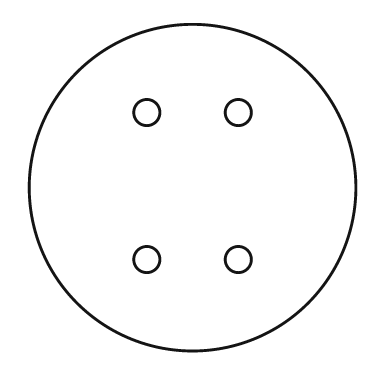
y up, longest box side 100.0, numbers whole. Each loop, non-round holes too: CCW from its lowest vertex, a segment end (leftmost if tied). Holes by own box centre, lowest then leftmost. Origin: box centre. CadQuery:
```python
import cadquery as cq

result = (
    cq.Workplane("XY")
    .moveTo(0.0, 0.0)
    .circle(50.0)
    .moveTo(-14.0, -22.0)
    .circle(4.0)
    .moveTo(14.0, -22.0)
    .circle(4.0)
    .moveTo(-14.0, 23.0)
    .circle(4.0)
    .moveTo(14.0, 23.0)
    .circle(4.0)
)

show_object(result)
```